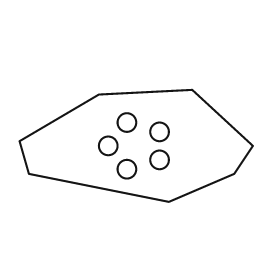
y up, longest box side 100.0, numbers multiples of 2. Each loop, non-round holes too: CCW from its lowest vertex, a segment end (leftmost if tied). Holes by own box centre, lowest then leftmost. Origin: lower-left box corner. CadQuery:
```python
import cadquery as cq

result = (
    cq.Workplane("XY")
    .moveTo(64.0, 0.0)
    .lineTo(92.0, 12.0)
    .lineTo(100.0, 24.0)
    .lineTo(74.0, 48.0)
    .lineTo(34.0, 46.0)
    .lineTo(0.0, 26.0)
    .lineTo(4.0, 12.0)
    .close()
    .moveTo(46.0, 14.0)
    .circle(4.0)
    .moveTo(60.0, 18.0)
    .circle(4.0)
    .moveTo(38.0, 24.0)
    .circle(4.0)
    .moveTo(60.0, 30.0)
    .circle(4.0)
    .moveTo(46.0, 34.0)
    .circle(4.0)
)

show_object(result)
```